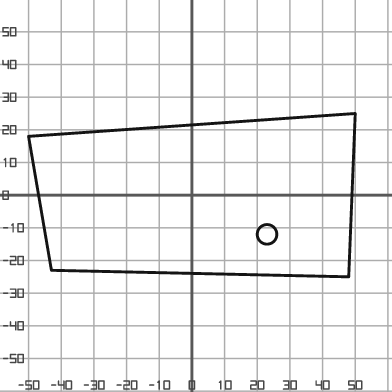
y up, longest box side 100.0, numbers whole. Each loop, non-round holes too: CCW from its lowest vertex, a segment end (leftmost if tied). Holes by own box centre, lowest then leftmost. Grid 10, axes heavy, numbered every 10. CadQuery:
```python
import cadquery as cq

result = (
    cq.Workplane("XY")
    .moveTo(48.0, -25.0)
    .lineTo(50.0, 25.0)
    .lineTo(-50.0, 18.0)
    .lineTo(-43.0, -23.0)
    .close()
    .moveTo(23.0, -12.0)
    .circle(3.0)
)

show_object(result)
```